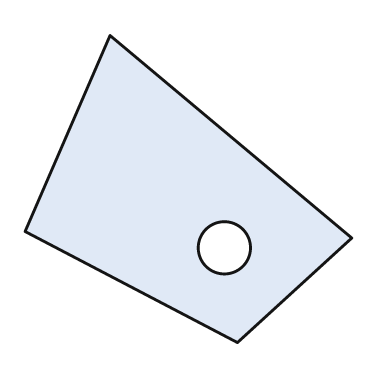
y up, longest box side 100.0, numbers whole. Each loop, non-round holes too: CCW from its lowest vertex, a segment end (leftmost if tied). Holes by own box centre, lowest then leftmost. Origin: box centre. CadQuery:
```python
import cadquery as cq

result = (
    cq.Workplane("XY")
    .moveTo(15.0, -47.0)
    .lineTo(50.0, -15.0)
    .lineTo(-24.0, 47.0)
    .lineTo(-50.0, -13.0)
    .close()
    .moveTo(11.0, -18.0)
    .circle(8.0)
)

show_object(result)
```